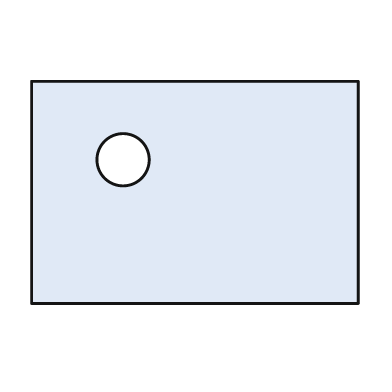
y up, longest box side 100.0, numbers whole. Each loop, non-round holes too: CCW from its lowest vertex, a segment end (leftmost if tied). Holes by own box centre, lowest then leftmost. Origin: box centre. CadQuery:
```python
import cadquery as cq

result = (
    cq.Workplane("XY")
    .moveTo(-50.0, -34.0)
    .lineTo(50.0, -34.0)
    .lineTo(50.0, 34.0)
    .lineTo(-50.0, 34.0)
    .close()
    .moveTo(-22.0, 10.0)
    .circle(8.0)
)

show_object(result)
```